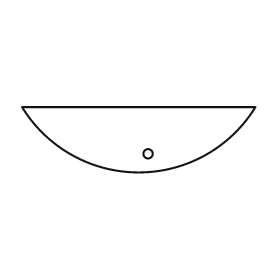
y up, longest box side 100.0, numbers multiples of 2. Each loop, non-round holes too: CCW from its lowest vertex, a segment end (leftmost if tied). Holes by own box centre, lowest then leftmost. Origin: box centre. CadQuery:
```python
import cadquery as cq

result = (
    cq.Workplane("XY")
    .moveTo(-50.0, 14.0)
    .threePointArc((0.0, -14.0), (50.0, 14.0))
    .close()
    .moveTo(4.0, -6.0)
    .circle(2.0)
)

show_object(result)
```